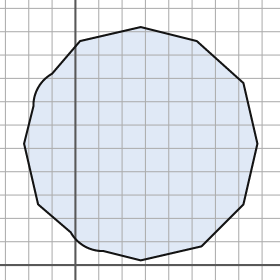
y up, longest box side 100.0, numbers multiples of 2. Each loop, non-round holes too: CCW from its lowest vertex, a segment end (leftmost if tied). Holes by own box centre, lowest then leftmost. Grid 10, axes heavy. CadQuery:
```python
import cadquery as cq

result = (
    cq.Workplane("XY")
    .moveTo(28.0, 2.0)
    .lineTo(54.0, 8.0)
    .lineTo(72.0, 26.0)
    .lineTo(78.0, 52.0)
    .lineTo(72.0, 78.0)
    .lineTo(52.0, 96.0)
    .lineTo(28.0, 102.0)
    .lineTo(2.0, 96.0)
    .lineTo(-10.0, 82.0)
    .threePointArc((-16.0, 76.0), (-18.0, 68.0))
    .lineTo(-22.0, 52.0)
    .lineTo(-16.0, 26.0)
    .lineTo(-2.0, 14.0)
    .threePointArc((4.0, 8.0), (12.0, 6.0))
    .close()
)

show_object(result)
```